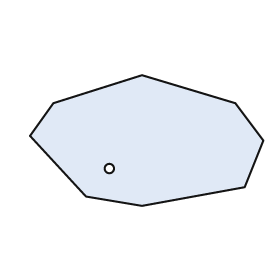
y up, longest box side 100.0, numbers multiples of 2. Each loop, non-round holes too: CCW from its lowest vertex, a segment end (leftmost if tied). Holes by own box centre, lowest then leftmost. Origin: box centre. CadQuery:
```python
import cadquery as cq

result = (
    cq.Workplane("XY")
    .moveTo(-2.0, -28.0)
    .lineTo(42.0, -20.0)
    .lineTo(50.0, 0.0)
    .lineTo(38.0, 16.0)
    .lineTo(-2.0, 28.0)
    .lineTo(-40.0, 16.0)
    .lineTo(-50.0, 2.0)
    .lineTo(-26.0, -24.0)
    .close()
    .moveTo(-16.0, -12.0)
    .circle(2.0)
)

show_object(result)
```